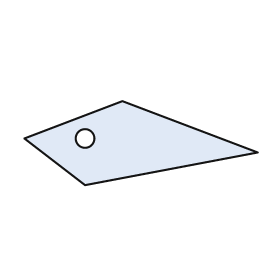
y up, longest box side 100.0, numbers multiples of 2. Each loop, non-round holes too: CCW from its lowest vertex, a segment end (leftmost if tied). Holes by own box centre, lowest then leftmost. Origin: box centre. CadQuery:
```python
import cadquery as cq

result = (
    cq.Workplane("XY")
    .moveTo(-24.0, -18.0)
    .lineTo(50.0, -4.0)
    .lineTo(-8.0, 18.0)
    .lineTo(-50.0, 2.0)
    .close()
    .moveTo(-24.0, 2.0)
    .circle(4.0)
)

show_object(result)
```